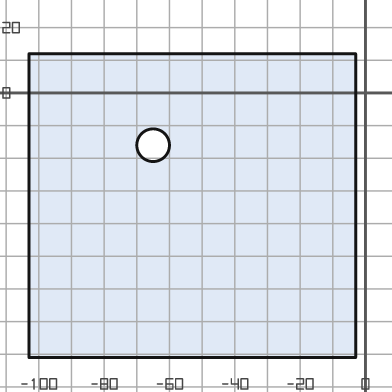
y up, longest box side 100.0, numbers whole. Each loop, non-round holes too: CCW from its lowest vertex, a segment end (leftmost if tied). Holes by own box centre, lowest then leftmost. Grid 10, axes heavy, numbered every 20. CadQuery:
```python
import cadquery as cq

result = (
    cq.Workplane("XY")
    .moveTo(-103.0, -81.0)
    .lineTo(-3.0, -81.0)
    .lineTo(-3.0, 12.0)
    .lineTo(-103.0, 12.0)
    .close()
    .moveTo(-65.0, -16.0)
    .circle(5.0)
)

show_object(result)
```